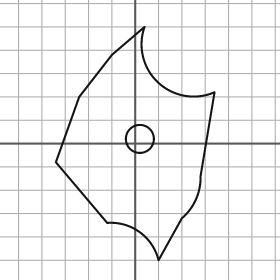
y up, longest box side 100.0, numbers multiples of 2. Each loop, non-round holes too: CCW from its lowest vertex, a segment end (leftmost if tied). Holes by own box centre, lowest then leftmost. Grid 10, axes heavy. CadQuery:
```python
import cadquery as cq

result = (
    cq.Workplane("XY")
    .moveTo(10.0, -50.0)
    .lineTo(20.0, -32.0)
    .threePointArc((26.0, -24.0), (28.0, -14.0))
    .lineTo(34.0, 22.0)
    .threePointArc((10.0, 26.0), (4.0, 50.0))
    .lineTo(-10.0, 38.0)
    .lineTo(-24.0, 20.0)
    .lineTo(-34.0, -8.0)
    .lineTo(-12.0, -34.0)
    .threePointArc((2.0, -38.0), (10.0, -50.0))
    .close()
    .moveTo(2.0, 2.0)
    .circle(6.0)
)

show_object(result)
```